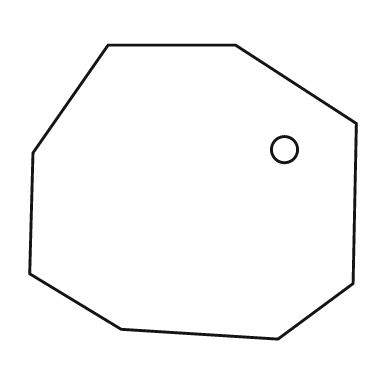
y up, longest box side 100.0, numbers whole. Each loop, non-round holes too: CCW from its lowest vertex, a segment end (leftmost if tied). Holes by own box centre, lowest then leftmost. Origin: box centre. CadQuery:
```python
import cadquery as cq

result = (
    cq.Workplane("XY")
    .moveTo(26.0, -45.0)
    .lineTo(49.0, -28.0)
    .lineTo(50.0, 21.0)
    .lineTo(13.0, 45.0)
    .lineTo(-26.0, 45.0)
    .lineTo(-49.0, 12.0)
    .lineTo(-50.0, -25.0)
    .lineTo(-22.0, -42.0)
    .close()
    .moveTo(28.0, 13.0)
    .circle(4.0)
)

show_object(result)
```